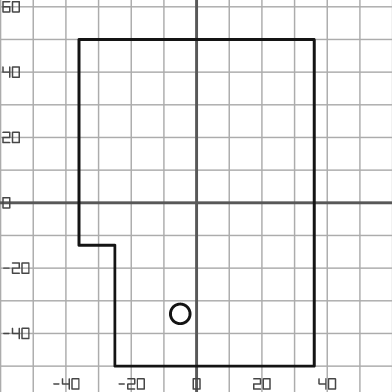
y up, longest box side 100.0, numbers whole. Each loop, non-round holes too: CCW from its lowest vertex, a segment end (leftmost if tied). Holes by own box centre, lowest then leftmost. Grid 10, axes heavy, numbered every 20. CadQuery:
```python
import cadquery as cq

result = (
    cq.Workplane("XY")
    .moveTo(-25.0, -50.0)
    .lineTo(36.0, -50.0)
    .lineTo(36.0, 50.0)
    .lineTo(-36.0, 50.0)
    .lineTo(-36.0, -13.0)
    .lineTo(-25.0, -13.0)
    .close()
    .moveTo(-5.0, -34.0)
    .circle(3.0)
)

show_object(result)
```